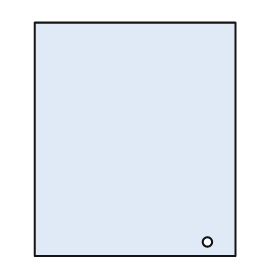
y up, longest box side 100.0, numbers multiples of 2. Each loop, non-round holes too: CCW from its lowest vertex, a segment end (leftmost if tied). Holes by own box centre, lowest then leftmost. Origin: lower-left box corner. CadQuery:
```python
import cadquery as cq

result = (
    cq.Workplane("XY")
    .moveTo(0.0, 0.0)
    .lineTo(86.0, 0.0)
    .lineTo(86.0, 100.0)
    .lineTo(0.0, 100.0)
    .close()
    .moveTo(74.0, 6.0)
    .circle(2.0)
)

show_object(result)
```